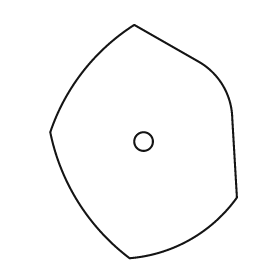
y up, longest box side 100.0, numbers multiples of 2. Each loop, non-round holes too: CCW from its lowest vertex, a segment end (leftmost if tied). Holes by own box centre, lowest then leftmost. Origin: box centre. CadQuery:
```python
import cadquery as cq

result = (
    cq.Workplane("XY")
    .moveTo(-6.0, -50.0)
    .threePointArc((20.0, -42.0), (40.0, -24.0))
    .lineTo(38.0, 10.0)
    .threePointArc((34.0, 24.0), (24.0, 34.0))
    .lineTo(-4.0, 50.0)
    .threePointArc((-26.0, 30.0), (-40.0, 4.0))
    .threePointArc((-28.0, -26.0), (-6.0, -50.0))
    .close()
    .moveTo(0.0, 0.0)
    .circle(4.0)
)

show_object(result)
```